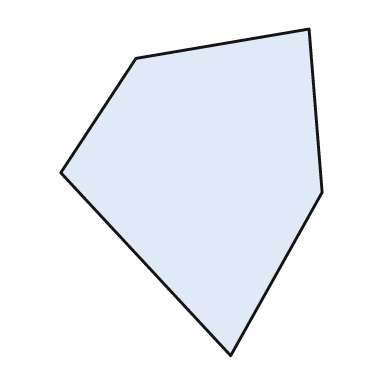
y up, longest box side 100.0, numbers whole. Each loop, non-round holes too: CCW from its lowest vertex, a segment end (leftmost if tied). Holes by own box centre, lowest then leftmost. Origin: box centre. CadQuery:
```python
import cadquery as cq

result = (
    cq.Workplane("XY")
    .moveTo(12.0, -50.0)
    .lineTo(40.0, 0.0)
    .lineTo(36.0, 50.0)
    .lineTo(-17.0, 41.0)
    .lineTo(-40.0, 6.0)
    .close()
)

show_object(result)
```